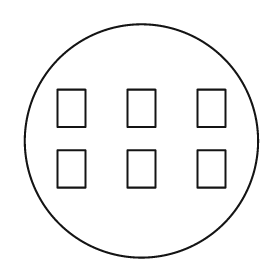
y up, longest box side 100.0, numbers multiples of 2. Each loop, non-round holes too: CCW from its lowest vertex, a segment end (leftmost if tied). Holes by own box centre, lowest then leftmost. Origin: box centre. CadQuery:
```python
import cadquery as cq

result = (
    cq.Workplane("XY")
    .moveTo(0.0, 0.0)
    .circle(50.0)
    .moveTo(-36.0, -20.0)
    .lineTo(-24.0, -20.0)
    .lineTo(-24.0, -4.0)
    .lineTo(-36.0, -4.0)
    .close()
    .moveTo(-6.0, -20.0)
    .lineTo(6.0, -20.0)
    .lineTo(6.0, -4.0)
    .lineTo(-6.0, -4.0)
    .close()
    .moveTo(24.0, -20.0)
    .lineTo(36.0, -20.0)
    .lineTo(36.0, -4.0)
    .lineTo(24.0, -4.0)
    .close()
    .moveTo(-36.0, 6.0)
    .lineTo(-24.0, 6.0)
    .lineTo(-24.0, 22.0)
    .lineTo(-36.0, 22.0)
    .close()
    .moveTo(-6.0, 6.0)
    .lineTo(6.0, 6.0)
    .lineTo(6.0, 22.0)
    .lineTo(-6.0, 22.0)
    .close()
    .moveTo(24.0, 6.0)
    .lineTo(36.0, 6.0)
    .lineTo(36.0, 22.0)
    .lineTo(24.0, 22.0)
    .close()
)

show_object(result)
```